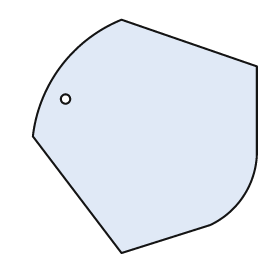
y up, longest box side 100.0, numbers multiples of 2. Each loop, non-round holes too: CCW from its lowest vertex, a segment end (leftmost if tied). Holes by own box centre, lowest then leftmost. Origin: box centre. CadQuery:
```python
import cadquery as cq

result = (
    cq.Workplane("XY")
    .moveTo(-10.0, -50.0)
    .lineTo(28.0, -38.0)
    .threePointArc((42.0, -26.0), (48.0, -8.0))
    .lineTo(48.0, 30.0)
    .lineTo(-10.0, 50.0)
    .threePointArc((-36.0, 30.0), (-48.0, 0.0))
    .close()
    .moveTo(-34.0, 16.0)
    .circle(2.0)
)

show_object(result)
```